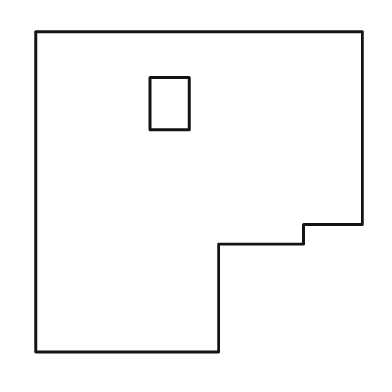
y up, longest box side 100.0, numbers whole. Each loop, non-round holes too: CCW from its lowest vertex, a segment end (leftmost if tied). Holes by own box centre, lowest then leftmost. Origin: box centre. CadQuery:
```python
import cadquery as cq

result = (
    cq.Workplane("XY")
    .moveTo(-50.0, -49.0)
    .lineTo(6.0, -49.0)
    .lineTo(6.0, -16.0)
    .lineTo(32.0, -16.0)
    .lineTo(32.0, -10.0)
    .lineTo(50.0, -10.0)
    .lineTo(50.0, 49.0)
    .lineTo(-50.0, 49.0)
    .close()
    .moveTo(-15.0, 19.0)
    .lineTo(-3.0, 19.0)
    .lineTo(-3.0, 35.0)
    .lineTo(-15.0, 35.0)
    .close()
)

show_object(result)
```